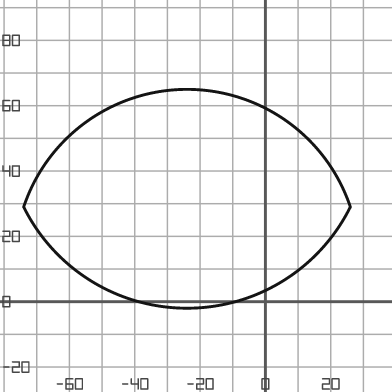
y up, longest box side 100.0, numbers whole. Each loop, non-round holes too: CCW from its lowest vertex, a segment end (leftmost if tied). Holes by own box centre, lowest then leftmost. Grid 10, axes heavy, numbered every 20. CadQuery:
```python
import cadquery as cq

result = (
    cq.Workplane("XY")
    .moveTo(-74.0, 29.0)
    .threePointArc((-24.0, -2.0), (26.0, 29.0))
    .threePointArc((-24.0, 65.0), (-74.0, 29.0))
    .close()
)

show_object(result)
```